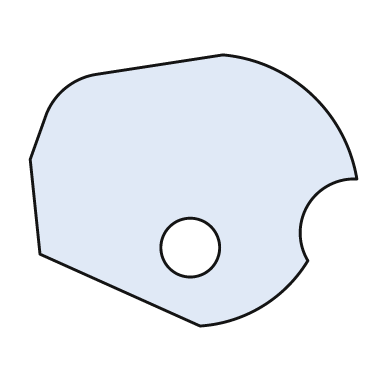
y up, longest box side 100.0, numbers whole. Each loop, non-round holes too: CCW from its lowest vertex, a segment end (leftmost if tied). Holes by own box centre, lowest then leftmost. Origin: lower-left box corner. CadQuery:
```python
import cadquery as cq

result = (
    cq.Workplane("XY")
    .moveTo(52.0, 0.0)
    .threePointArc((71.0, 6.0), (85.0, 20.0))
    .threePointArc((85.0, 37.0), (100.0, 45.0))
    .threePointArc((86.0, 71.0), (59.0, 83.0))
    .lineTo(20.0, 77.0)
    .threePointArc((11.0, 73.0), (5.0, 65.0))
    .lineTo(0.0, 51.0)
    .lineTo(3.0, 22.0)
    .close()
    .moveTo(49.0, 24.0)
    .circle(9.0)
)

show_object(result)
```